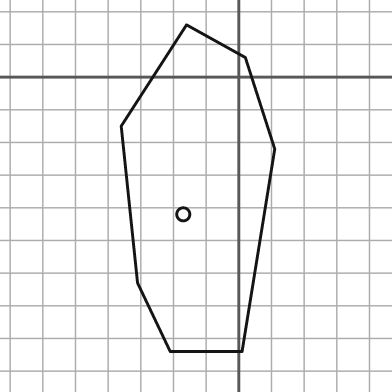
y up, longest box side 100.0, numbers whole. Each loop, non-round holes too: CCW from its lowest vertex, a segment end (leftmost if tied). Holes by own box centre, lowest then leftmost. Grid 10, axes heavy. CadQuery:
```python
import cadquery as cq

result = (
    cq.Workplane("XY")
    .moveTo(-21.0, -84.0)
    .lineTo(1.0, -84.0)
    .lineTo(11.0, -22.0)
    .lineTo(2.0, 6.0)
    .lineTo(-16.0, 16.0)
    .lineTo(-36.0, -15.0)
    .lineTo(-31.0, -63.0)
    .close()
    .moveTo(-17.0, -42.0)
    .circle(2.0)
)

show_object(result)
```